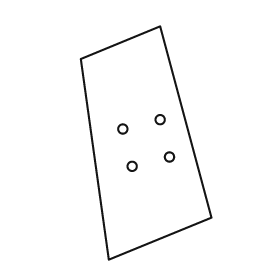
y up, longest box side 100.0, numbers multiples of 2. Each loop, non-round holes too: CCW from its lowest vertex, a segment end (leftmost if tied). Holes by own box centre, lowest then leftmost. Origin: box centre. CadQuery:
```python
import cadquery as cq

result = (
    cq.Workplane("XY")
    .moveTo(-16.0, -50.0)
    .lineTo(28.0, -32.0)
    .lineTo(6.0, 50.0)
    .lineTo(-28.0, 36.0)
    .close()
    .moveTo(-6.0, -10.0)
    .circle(2.0)
    .moveTo(10.0, -6.0)
    .circle(2.0)
    .moveTo(-10.0, 6.0)
    .circle(2.0)
    .moveTo(6.0, 10.0)
    .circle(2.0)
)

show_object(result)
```